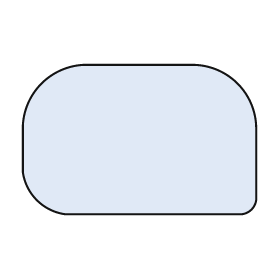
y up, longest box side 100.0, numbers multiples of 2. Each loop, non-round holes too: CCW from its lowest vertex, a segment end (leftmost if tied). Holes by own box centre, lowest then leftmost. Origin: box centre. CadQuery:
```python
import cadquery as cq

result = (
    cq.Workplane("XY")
    .moveTo(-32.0, -32.0)
    .lineTo(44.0, -32.0)
    .threePointArc((48.0, -30.0), (50.0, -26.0))
    .lineTo(50.0, 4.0)
    .threePointArc((42.0, 24.0), (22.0, 32.0))
    .lineTo(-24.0, 32.0)
    .threePointArc((-42.0, 24.0), (-50.0, 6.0))
    .lineTo(-50.0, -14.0)
    .threePointArc((-44.0, -26.0), (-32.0, -32.0))
    .close()
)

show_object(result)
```